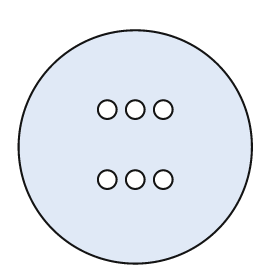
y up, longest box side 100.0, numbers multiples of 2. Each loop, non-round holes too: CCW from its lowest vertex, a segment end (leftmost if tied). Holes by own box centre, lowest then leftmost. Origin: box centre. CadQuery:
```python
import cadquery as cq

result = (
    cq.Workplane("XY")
    .moveTo(0.0, 0.0)
    .circle(50.0)
    .moveTo(-12.0, -14.0)
    .circle(4.0)
    .moveTo(0.0, -14.0)
    .circle(4.0)
    .moveTo(12.0, -14.0)
    .circle(4.0)
    .moveTo(-12.0, 16.0)
    .circle(4.0)
    .moveTo(0.0, 16.0)
    .circle(4.0)
    .moveTo(12.0, 16.0)
    .circle(4.0)
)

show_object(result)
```